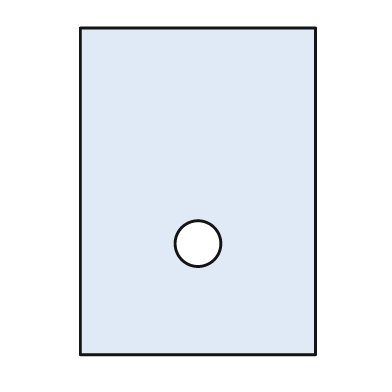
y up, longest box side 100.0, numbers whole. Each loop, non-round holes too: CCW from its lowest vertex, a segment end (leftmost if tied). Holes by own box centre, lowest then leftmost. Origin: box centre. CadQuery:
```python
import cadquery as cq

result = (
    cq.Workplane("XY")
    .moveTo(-36.0, -50.0)
    .lineTo(36.0, -50.0)
    .lineTo(36.0, 50.0)
    .lineTo(-36.0, 50.0)
    .close()
    .moveTo(0.0, -16.0)
    .circle(7.0)
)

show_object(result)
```